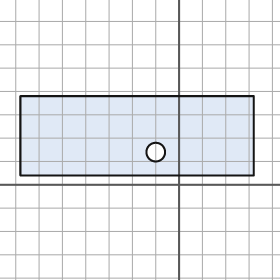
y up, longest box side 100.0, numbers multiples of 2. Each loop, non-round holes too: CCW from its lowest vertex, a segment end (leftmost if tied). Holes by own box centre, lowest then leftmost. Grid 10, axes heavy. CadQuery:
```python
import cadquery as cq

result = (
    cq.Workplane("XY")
    .moveTo(-68.0, 4.0)
    .lineTo(32.0, 4.0)
    .lineTo(32.0, 38.0)
    .lineTo(-68.0, 38.0)
    .close()
    .moveTo(-10.0, 14.0)
    .circle(4.0)
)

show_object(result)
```